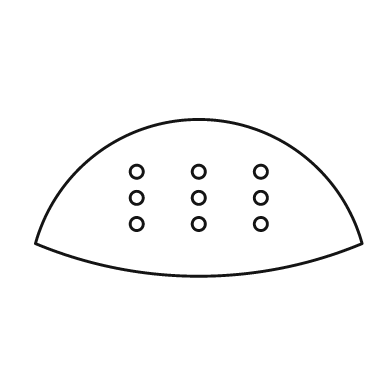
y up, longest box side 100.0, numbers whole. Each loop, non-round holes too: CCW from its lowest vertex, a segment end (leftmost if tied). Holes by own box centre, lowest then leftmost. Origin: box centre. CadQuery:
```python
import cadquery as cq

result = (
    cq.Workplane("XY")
    .moveTo(-50.0, -14.0)
    .threePointArc((0.0, -24.0), (50.0, -14.0))
    .threePointArc((0.0, 24.0), (-50.0, -14.0))
    .close()
    .moveTo(-19.0, -8.0)
    .circle(2.0)
    .moveTo(0.0, -8.0)
    .circle(2.0)
    .moveTo(19.0, -8.0)
    .circle(2.0)
    .moveTo(-19.0, 0.0)
    .circle(2.0)
    .moveTo(0.0, 0.0)
    .circle(2.0)
    .moveTo(19.0, 0.0)
    .circle(2.0)
    .moveTo(-19.0, 8.0)
    .circle(2.0)
    .moveTo(0.0, 8.0)
    .circle(2.0)
    .moveTo(19.0, 8.0)
    .circle(2.0)
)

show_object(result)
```